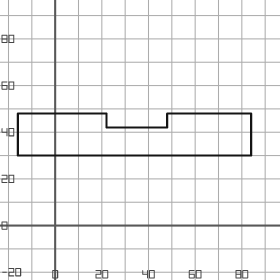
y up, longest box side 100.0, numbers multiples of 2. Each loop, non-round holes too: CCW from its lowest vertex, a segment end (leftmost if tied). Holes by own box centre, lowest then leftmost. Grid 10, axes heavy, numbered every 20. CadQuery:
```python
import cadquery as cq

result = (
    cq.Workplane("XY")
    .moveTo(-16.0, 30.0)
    .lineTo(84.0, 30.0)
    .lineTo(84.0, 48.0)
    .lineTo(48.0, 48.0)
    .lineTo(48.0, 42.0)
    .lineTo(22.0, 42.0)
    .lineTo(22.0, 48.0)
    .lineTo(-16.0, 48.0)
    .close()
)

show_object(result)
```